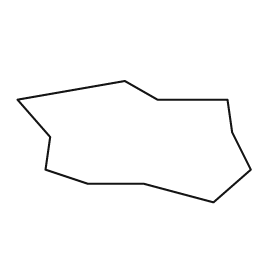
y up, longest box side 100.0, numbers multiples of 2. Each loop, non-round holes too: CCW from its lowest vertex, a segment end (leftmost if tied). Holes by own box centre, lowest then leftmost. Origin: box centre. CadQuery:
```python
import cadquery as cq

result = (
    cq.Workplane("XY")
    .moveTo(34.0, -26.0)
    .lineTo(50.0, -12.0)
    .lineTo(42.0, 4.0)
    .lineTo(40.0, 18.0)
    .lineTo(10.0, 18.0)
    .lineTo(-4.0, 26.0)
    .lineTo(-50.0, 18.0)
    .lineTo(-36.0, 2.0)
    .lineTo(-38.0, -12.0)
    .lineTo(-20.0, -18.0)
    .lineTo(4.0, -18.0)
    .close()
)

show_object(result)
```